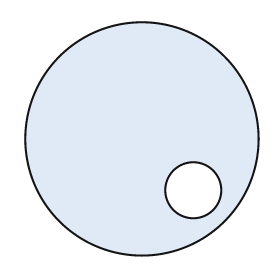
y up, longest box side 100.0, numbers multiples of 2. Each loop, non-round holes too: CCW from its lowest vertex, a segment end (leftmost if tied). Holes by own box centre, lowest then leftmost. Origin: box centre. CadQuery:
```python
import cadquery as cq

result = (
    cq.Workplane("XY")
    .moveTo(0.0, 0.0)
    .circle(50.0)
    .moveTo(22.0, -22.0)
    .circle(12.0)
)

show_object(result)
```